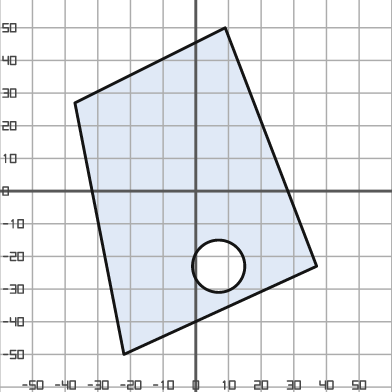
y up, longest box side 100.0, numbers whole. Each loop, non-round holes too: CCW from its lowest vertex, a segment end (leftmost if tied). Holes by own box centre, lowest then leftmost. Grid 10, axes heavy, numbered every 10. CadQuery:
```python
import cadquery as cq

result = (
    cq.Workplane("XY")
    .moveTo(-22.0, -50.0)
    .lineTo(37.0, -23.0)
    .lineTo(9.0, 50.0)
    .lineTo(-37.0, 27.0)
    .close()
    .moveTo(7.0, -23.0)
    .circle(8.0)
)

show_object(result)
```